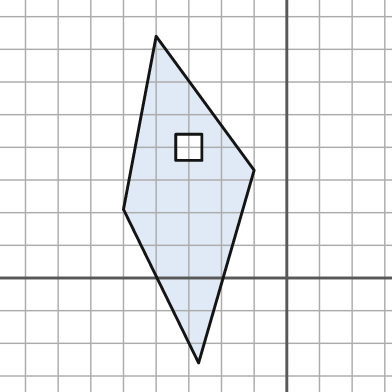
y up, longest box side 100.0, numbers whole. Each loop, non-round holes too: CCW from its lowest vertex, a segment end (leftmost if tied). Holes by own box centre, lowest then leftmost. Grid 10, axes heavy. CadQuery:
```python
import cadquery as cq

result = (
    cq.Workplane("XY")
    .moveTo(-27.0, -26.0)
    .lineTo(-10.0, 33.0)
    .lineTo(-40.0, 74.0)
    .lineTo(-50.0, 21.0)
    .close()
    .moveTo(-34.0, 36.0)
    .lineTo(-26.0, 36.0)
    .lineTo(-26.0, 44.0)
    .lineTo(-34.0, 44.0)
    .close()
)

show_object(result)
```